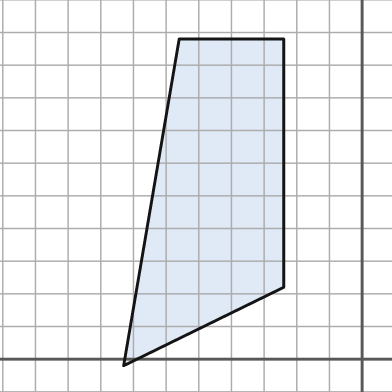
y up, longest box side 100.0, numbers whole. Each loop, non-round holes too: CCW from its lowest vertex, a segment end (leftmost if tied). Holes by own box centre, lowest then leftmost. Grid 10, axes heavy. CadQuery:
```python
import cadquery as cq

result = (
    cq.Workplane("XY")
    .moveTo(-73.0, -2.0)
    .lineTo(-24.0, 22.0)
    .lineTo(-24.0, 98.0)
    .lineTo(-56.0, 98.0)
    .close()
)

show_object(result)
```